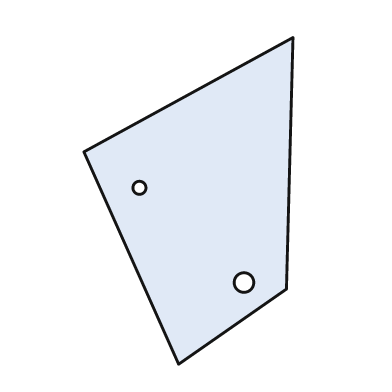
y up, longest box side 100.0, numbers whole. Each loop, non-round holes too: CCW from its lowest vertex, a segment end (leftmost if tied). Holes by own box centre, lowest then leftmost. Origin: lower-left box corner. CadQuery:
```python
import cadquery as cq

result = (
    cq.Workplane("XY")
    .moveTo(29.0, 0.0)
    .lineTo(62.0, 23.0)
    .lineTo(64.0, 100.0)
    .lineTo(0.0, 65.0)
    .close()
    .moveTo(49.0, 25.0)
    .circle(3.0)
    .moveTo(17.0, 54.0)
    .circle(2.0)
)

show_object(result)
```